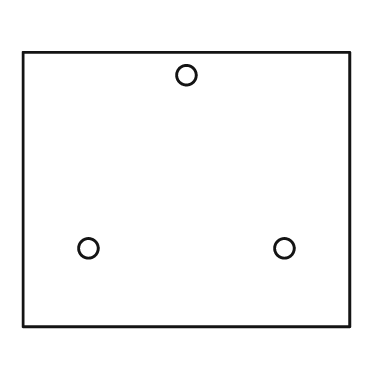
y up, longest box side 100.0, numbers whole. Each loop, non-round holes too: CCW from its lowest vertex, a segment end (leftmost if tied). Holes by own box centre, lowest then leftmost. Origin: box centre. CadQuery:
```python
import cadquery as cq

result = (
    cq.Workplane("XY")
    .moveTo(-50.0, -42.0)
    .lineTo(50.0, -42.0)
    .lineTo(50.0, 42.0)
    .lineTo(-50.0, 42.0)
    .close()
    .moveTo(-30.0, -18.0)
    .circle(3.0)
    .moveTo(30.0, -18.0)
    .circle(3.0)
    .moveTo(0.0, 35.0)
    .circle(3.0)
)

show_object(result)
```